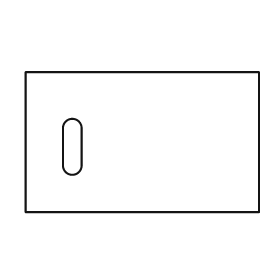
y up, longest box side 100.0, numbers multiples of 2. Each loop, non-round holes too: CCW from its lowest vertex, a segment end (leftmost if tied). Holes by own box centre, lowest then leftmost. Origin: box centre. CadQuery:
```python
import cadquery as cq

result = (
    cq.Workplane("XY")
    .moveTo(-50.0, -30.0)
    .lineTo(50.0, -30.0)
    .lineTo(50.0, 30.0)
    .lineTo(-50.0, 30.0)
    .close()
    .moveTo(-34.0, -10.0)
    .threePointArc((-30.0, -14.0), (-26.0, -10.0))
    .lineTo(-26.0, 6.0)
    .threePointArc((-30.0, 10.0), (-34.0, 6.0))
    .close()
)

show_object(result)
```